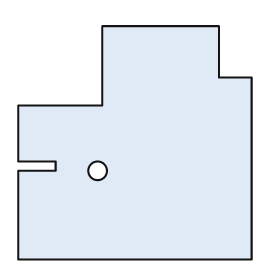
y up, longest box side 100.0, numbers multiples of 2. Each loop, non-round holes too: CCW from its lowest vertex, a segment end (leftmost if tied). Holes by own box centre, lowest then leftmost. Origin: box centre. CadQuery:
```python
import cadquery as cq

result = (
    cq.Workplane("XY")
    .moveTo(-50.0, -50.0)
    .lineTo(50.0, -50.0)
    .lineTo(50.0, 28.0)
    .lineTo(36.0, 28.0)
    .lineTo(36.0, 50.0)
    .lineTo(-14.0, 50.0)
    .lineTo(-14.0, 16.0)
    .lineTo(-50.0, 16.0)
    .lineTo(-50.0, -8.0)
    .lineTo(-34.0, -8.0)
    .lineTo(-34.0, -12.0)
    .lineTo(-50.0, -12.0)
    .close()
    .moveTo(-16.0, -12.0)
    .circle(4.0)
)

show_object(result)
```